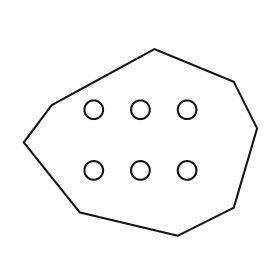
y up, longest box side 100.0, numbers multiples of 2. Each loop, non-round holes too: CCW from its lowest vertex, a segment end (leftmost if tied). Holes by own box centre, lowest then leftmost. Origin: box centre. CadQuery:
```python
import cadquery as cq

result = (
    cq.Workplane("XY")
    .moveTo(16.0, -40.0)
    .lineTo(40.0, -28.0)
    .lineTo(50.0, 6.0)
    .lineTo(40.0, 26.0)
    .lineTo(6.0, 40.0)
    .lineTo(-38.0, 16.0)
    .lineTo(-50.0, 0.0)
    .lineTo(-26.0, -30.0)
    .close()
    .moveTo(-20.0, -12.0)
    .circle(4.0)
    .moveTo(0.0, -12.0)
    .circle(4.0)
    .moveTo(20.0, -12.0)
    .circle(4.0)
    .moveTo(-20.0, 14.0)
    .circle(4.0)
    .moveTo(0.0, 14.0)
    .circle(4.0)
    .moveTo(20.0, 14.0)
    .circle(4.0)
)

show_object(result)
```